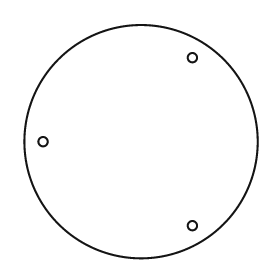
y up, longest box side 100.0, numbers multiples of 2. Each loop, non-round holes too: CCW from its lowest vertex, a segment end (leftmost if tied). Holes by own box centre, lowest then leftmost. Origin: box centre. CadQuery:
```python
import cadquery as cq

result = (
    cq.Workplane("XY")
    .moveTo(0.0, 0.0)
    .circle(50.0)
    .moveTo(22.0, -36.0)
    .circle(2.0)
    .moveTo(-42.0, 0.0)
    .circle(2.0)
    .moveTo(22.0, 36.0)
    .circle(2.0)
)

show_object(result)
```